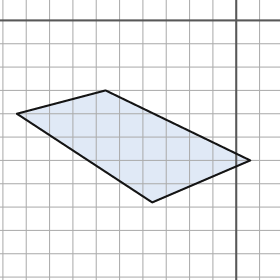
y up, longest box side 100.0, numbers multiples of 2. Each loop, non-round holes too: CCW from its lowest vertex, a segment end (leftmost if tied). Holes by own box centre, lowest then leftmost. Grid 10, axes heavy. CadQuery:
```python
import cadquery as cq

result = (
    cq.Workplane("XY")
    .moveTo(-36.0, -78.0)
    .lineTo(6.0, -60.0)
    .lineTo(-56.0, -30.0)
    .lineTo(-94.0, -40.0)
    .close()
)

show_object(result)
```